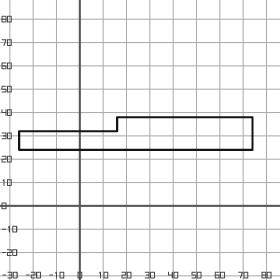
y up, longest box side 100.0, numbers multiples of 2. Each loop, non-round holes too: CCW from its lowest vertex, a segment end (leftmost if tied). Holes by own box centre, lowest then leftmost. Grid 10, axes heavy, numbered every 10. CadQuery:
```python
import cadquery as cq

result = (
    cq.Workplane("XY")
    .moveTo(-26.0, 24.0)
    .lineTo(74.0, 24.0)
    .lineTo(74.0, 38.0)
    .lineTo(16.0, 38.0)
    .lineTo(16.0, 32.0)
    .lineTo(-26.0, 32.0)
    .close()
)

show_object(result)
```